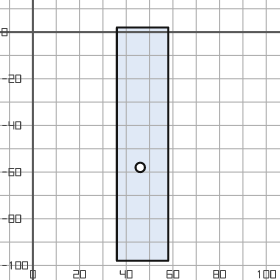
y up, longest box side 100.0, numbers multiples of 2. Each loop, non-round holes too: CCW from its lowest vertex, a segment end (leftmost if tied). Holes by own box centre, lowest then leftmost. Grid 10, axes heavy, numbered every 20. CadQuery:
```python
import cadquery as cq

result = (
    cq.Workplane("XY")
    .moveTo(36.0, -98.0)
    .lineTo(58.0, -98.0)
    .lineTo(58.0, 2.0)
    .lineTo(36.0, 2.0)
    .close()
    .moveTo(46.0, -58.0)
    .circle(2.0)
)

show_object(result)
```